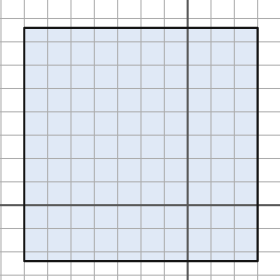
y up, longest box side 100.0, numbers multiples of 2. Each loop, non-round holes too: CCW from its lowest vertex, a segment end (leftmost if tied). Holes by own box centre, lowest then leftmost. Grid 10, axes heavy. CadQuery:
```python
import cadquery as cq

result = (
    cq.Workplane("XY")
    .moveTo(-70.0, -24.0)
    .lineTo(30.0, -24.0)
    .lineTo(30.0, 76.0)
    .lineTo(-70.0, 76.0)
    .close()
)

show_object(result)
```